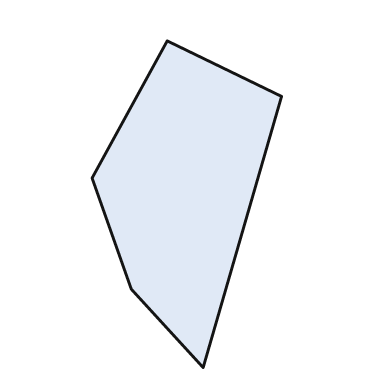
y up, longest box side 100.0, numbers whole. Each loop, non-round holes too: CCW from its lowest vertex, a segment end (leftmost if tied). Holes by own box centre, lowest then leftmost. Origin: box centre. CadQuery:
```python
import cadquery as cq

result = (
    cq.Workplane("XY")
    .moveTo(5.0, -50.0)
    .lineTo(29.0, 33.0)
    .lineTo(-6.0, 50.0)
    .lineTo(-29.0, 8.0)
    .lineTo(-17.0, -26.0)
    .close()
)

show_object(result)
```